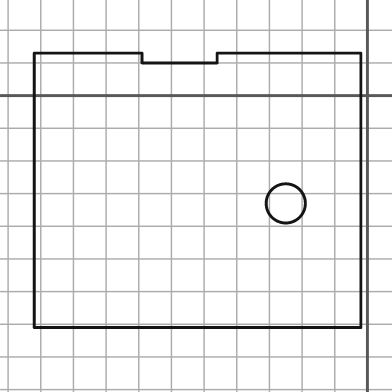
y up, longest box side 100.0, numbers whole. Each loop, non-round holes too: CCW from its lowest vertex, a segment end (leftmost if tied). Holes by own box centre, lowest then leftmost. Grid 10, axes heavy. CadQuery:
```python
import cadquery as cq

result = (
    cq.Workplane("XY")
    .moveTo(-102.0, -71.0)
    .lineTo(-2.0, -71.0)
    .lineTo(-2.0, 13.0)
    .lineTo(-46.0, 13.0)
    .lineTo(-46.0, 10.0)
    .lineTo(-69.0, 10.0)
    .lineTo(-69.0, 13.0)
    .lineTo(-102.0, 13.0)
    .close()
    .moveTo(-25.0, -33.0)
    .circle(6.0)
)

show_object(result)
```